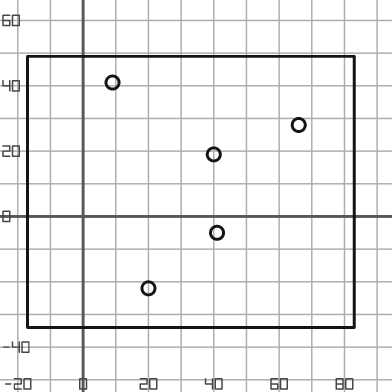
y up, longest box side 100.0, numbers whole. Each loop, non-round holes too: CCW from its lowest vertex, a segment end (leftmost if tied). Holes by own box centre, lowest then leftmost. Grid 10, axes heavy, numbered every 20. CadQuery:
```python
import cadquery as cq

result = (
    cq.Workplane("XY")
    .moveTo(-17.0, -34.0)
    .lineTo(83.0, -34.0)
    .lineTo(83.0, 49.0)
    .lineTo(-17.0, 49.0)
    .close()
    .moveTo(20.0, -22.0)
    .circle(2.0)
    .moveTo(41.0, -5.0)
    .circle(2.0)
    .moveTo(40.0, 19.0)
    .circle(2.0)
    .moveTo(66.0, 28.0)
    .circle(2.0)
    .moveTo(9.0, 41.0)
    .circle(2.0)
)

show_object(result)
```